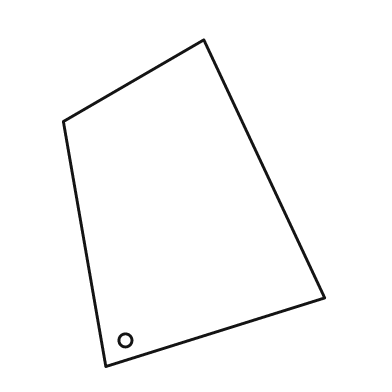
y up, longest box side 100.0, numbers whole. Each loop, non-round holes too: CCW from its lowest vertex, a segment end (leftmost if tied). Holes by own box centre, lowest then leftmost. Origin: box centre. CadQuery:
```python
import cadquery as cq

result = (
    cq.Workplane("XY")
    .moveTo(-27.0, -50.0)
    .lineTo(40.0, -29.0)
    .lineTo(3.0, 50.0)
    .lineTo(-40.0, 25.0)
    .close()
    .moveTo(-21.0, -42.0)
    .circle(2.0)
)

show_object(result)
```